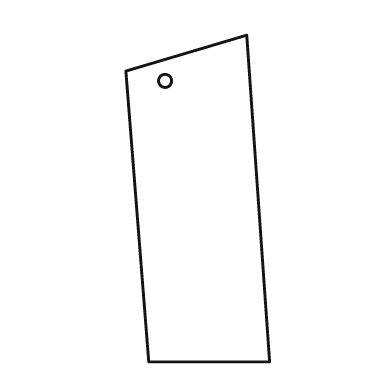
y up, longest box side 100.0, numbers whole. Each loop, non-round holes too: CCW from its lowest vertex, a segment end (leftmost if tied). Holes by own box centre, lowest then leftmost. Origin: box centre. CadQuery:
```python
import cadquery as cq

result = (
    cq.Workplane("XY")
    .moveTo(-15.0, -50.0)
    .lineTo(22.0, -50.0)
    .lineTo(15.0, 50.0)
    .lineTo(-22.0, 39.0)
    .close()
    .moveTo(-10.0, 36.0)
    .circle(2.0)
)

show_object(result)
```